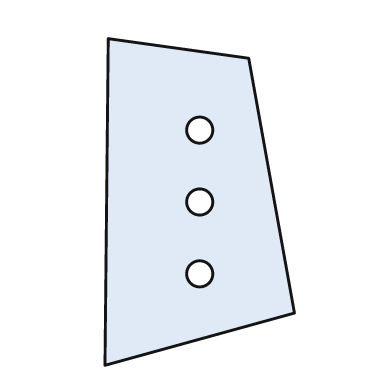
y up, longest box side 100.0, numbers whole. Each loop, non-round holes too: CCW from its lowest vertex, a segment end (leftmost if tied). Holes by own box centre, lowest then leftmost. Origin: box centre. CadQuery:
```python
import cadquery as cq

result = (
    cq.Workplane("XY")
    .moveTo(-29.0, -50.0)
    .lineTo(29.0, -34.0)
    .lineTo(15.0, 44.0)
    .lineTo(-28.0, 50.0)
    .close()
    .moveTo(0.0, -22.0)
    .circle(4.0)
    .moveTo(0.0, 0.0)
    .circle(4.0)
    .moveTo(0.0, 22.0)
    .circle(4.0)
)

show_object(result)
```